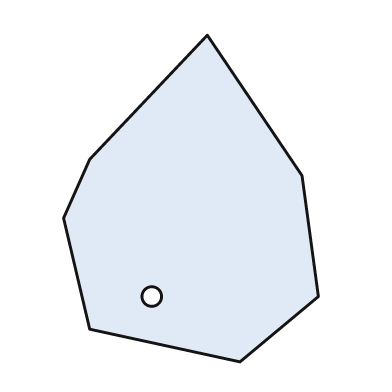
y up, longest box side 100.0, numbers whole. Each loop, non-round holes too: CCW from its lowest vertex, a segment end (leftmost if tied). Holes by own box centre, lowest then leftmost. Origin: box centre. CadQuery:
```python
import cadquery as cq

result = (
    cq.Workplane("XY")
    .moveTo(15.0, -50.0)
    .lineTo(39.0, -30.0)
    .lineTo(34.0, 7.0)
    .lineTo(5.0, 50.0)
    .lineTo(-31.0, 12.0)
    .lineTo(-39.0, -6.0)
    .lineTo(-31.0, -40.0)
    .close()
    .moveTo(-12.0, -30.0)
    .circle(3.0)
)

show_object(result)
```